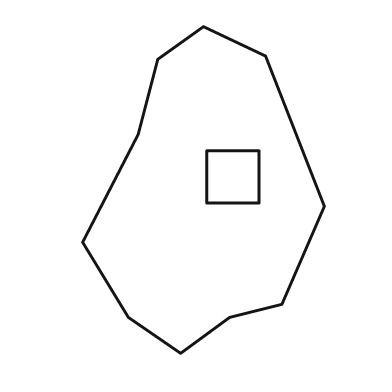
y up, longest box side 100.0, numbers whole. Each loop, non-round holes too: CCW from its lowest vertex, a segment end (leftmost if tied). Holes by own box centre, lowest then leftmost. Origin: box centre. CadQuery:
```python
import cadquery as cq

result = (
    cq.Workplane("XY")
    .moveTo(-7.0, -50.0)
    .lineTo(8.0, -39.0)
    .lineTo(24.0, -35.0)
    .lineTo(37.0, -5.0)
    .lineTo(19.0, 41.0)
    .lineTo(0.0, 50.0)
    .lineTo(-14.0, 40.0)
    .lineTo(-20.0, 17.0)
    .lineTo(-37.0, -16.0)
    .lineTo(-23.0, -39.0)
    .close()
    .moveTo(1.0, -4.0)
    .lineTo(17.0, -4.0)
    .lineTo(17.0, 12.0)
    .lineTo(1.0, 12.0)
    .close()
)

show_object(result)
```